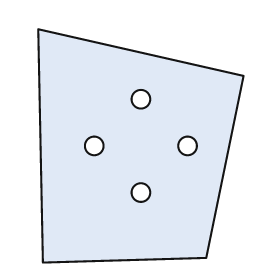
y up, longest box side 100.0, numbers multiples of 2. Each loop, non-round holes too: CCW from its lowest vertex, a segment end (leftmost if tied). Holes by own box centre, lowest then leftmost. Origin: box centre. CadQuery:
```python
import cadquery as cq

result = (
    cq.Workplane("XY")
    .moveTo(-42.0, -50.0)
    .lineTo(28.0, -48.0)
    .lineTo(44.0, 30.0)
    .lineTo(-44.0, 50.0)
    .close()
    .moveTo(0.0, -20.0)
    .circle(4.0)
    .moveTo(-20.0, 0.0)
    .circle(4.0)
    .moveTo(20.0, 0.0)
    .circle(4.0)
    .moveTo(0.0, 20.0)
    .circle(4.0)
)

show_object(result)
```